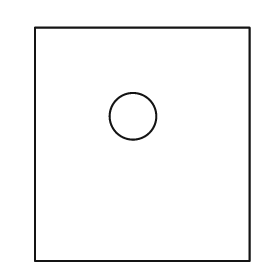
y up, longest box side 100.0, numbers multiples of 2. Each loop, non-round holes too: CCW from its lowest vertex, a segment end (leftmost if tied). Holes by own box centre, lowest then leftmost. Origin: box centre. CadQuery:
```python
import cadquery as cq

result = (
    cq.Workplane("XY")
    .moveTo(-46.0, -50.0)
    .lineTo(46.0, -50.0)
    .lineTo(46.0, 50.0)
    .lineTo(-46.0, 50.0)
    .close()
    .moveTo(-4.0, 12.0)
    .circle(10.0)
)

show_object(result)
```